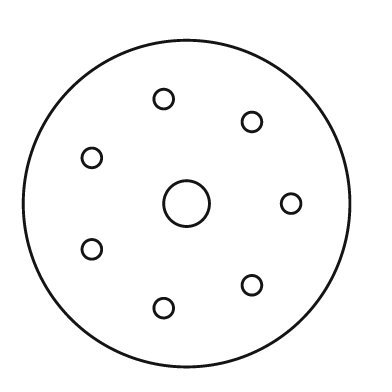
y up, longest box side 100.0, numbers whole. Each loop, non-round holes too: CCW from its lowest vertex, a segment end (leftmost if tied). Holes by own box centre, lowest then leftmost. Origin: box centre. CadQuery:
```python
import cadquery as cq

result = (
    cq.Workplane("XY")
    .moveTo(0.0, 0.0)
    .circle(50.0)
    .moveTo(-7.0, -32.0)
    .circle(3.0)
    .moveTo(20.0, -25.0)
    .circle(3.0)
    .moveTo(-29.0, -14.0)
    .circle(3.0)
    .moveTo(0.0, 0.0)
    .circle(7.0)
    .moveTo(32.0, 0.0)
    .circle(3.0)
    .moveTo(-29.0, 14.0)
    .circle(3.0)
    .moveTo(20.0, 25.0)
    .circle(3.0)
    .moveTo(-7.0, 32.0)
    .circle(3.0)
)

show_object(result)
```